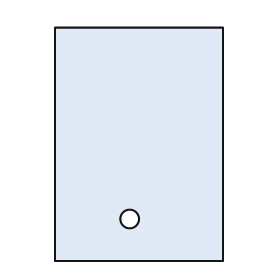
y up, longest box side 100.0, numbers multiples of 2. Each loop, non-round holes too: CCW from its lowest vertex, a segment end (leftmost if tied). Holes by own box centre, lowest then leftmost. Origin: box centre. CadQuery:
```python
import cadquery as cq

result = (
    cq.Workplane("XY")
    .moveTo(-36.0, -50.0)
    .lineTo(36.0, -50.0)
    .lineTo(36.0, 50.0)
    .lineTo(-36.0, 50.0)
    .close()
    .moveTo(-4.0, -32.0)
    .circle(4.0)
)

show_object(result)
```